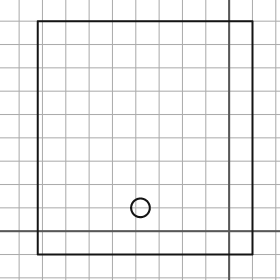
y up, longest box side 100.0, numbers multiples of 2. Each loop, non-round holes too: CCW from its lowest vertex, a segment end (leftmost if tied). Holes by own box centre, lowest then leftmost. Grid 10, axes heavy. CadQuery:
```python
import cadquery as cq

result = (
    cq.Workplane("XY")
    .moveTo(-82.0, -10.0)
    .lineTo(10.0, -10.0)
    .lineTo(10.0, 90.0)
    .lineTo(-82.0, 90.0)
    .close()
    .moveTo(-38.0, 10.0)
    .circle(4.0)
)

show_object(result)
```